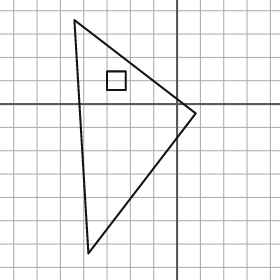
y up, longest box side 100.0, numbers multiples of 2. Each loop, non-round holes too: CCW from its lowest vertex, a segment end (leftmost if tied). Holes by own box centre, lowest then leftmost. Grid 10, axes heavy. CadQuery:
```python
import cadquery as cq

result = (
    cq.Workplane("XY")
    .moveTo(-38.0, -64.0)
    .lineTo(8.0, -4.0)
    .lineTo(-44.0, 36.0)
    .close()
    .moveTo(-30.0, 6.0)
    .lineTo(-22.0, 6.0)
    .lineTo(-22.0, 14.0)
    .lineTo(-30.0, 14.0)
    .close()
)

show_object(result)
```